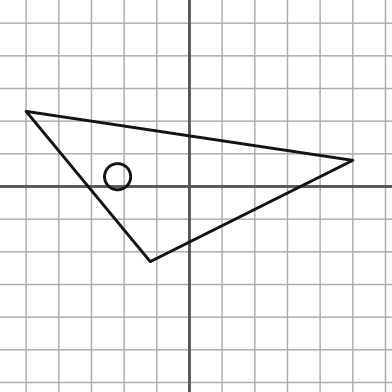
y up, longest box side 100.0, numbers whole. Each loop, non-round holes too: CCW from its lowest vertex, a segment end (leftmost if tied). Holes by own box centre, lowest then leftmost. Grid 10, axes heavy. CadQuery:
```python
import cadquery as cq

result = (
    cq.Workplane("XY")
    .moveTo(-12.0, -23.0)
    .lineTo(50.0, 8.0)
    .lineTo(-50.0, 23.0)
    .close()
    .moveTo(-22.0, 3.0)
    .circle(4.0)
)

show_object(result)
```